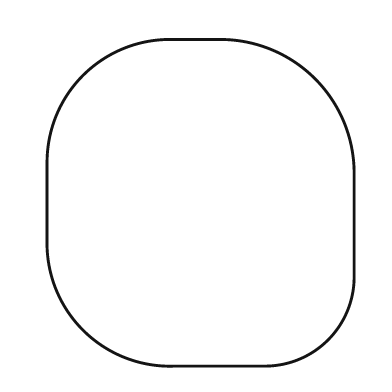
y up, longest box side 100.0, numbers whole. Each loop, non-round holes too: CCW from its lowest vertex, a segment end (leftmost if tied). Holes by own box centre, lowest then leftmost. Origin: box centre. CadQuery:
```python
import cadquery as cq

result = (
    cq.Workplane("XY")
    .moveTo(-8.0, -50.0)
    .lineTo(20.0, -50.0)
    .threePointArc((39.0, -42.0), (47.0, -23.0))
    .lineTo(47.0, 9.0)
    .threePointArc((35.0, 38.0), (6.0, 50.0))
    .lineTo(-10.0, 50.0)
    .threePointArc((-36.0, 39.0), (-47.0, 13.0))
    .lineTo(-47.0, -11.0)
    .threePointArc((-36.0, -39.0), (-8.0, -50.0))
    .close()
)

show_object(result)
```